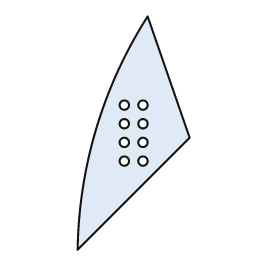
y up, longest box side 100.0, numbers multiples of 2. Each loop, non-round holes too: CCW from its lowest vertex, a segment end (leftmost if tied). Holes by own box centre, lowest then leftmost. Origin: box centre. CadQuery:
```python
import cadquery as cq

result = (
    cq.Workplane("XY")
    .moveTo(-24.0, -50.0)
    .lineTo(24.0, -2.0)
    .lineTo(6.0, 50.0)
    .threePointArc((-16.0, 2.0), (-24.0, -50.0))
    .close()
    .moveTo(-4.0, -12.0)
    .circle(2.0)
    .moveTo(4.0, -12.0)
    .circle(2.0)
    .moveTo(-4.0, -4.0)
    .circle(2.0)
    .moveTo(4.0, -4.0)
    .circle(2.0)
    .moveTo(-4.0, 4.0)
    .circle(2.0)
    .moveTo(4.0, 4.0)
    .circle(2.0)
    .moveTo(-4.0, 12.0)
    .circle(2.0)
    .moveTo(4.0, 12.0)
    .circle(2.0)
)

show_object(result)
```